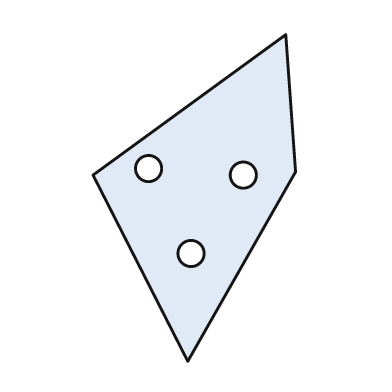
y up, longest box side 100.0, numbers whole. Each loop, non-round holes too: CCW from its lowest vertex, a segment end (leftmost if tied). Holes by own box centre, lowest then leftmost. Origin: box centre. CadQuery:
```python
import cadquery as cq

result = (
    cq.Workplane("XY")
    .moveTo(-2.0, -50.0)
    .lineTo(31.0, 8.0)
    .lineTo(28.0, 50.0)
    .lineTo(-31.0, 7.0)
    .close()
    .moveTo(-1.0, -17.0)
    .circle(4.0)
    .moveTo(15.0, 7.0)
    .circle(4.0)
    .moveTo(-14.0, 9.0)
    .circle(4.0)
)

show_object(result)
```